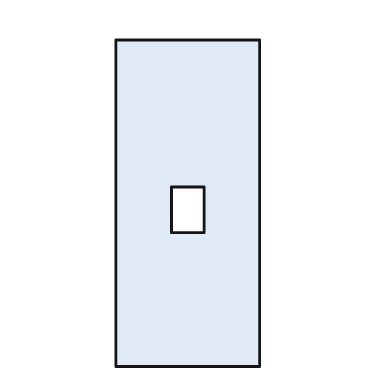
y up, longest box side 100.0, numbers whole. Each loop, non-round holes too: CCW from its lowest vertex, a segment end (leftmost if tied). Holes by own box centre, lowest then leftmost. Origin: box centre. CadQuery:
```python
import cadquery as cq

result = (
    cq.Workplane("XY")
    .moveTo(-22.0, -50.0)
    .lineTo(22.0, -50.0)
    .lineTo(22.0, 50.0)
    .lineTo(-22.0, 50.0)
    .close()
    .moveTo(-5.0, -9.0)
    .lineTo(5.0, -9.0)
    .lineTo(5.0, 5.0)
    .lineTo(-5.0, 5.0)
    .close()
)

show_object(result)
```